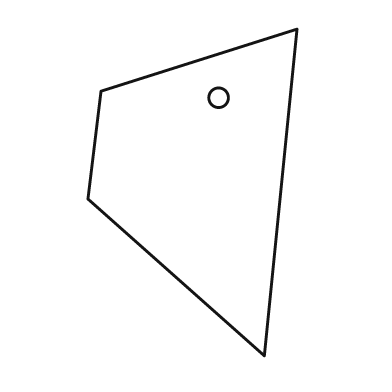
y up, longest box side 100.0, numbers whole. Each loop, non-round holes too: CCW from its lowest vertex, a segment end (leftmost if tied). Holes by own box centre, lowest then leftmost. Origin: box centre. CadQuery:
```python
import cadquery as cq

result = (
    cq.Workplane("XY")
    .moveTo(22.0, -50.0)
    .lineTo(32.0, 50.0)
    .lineTo(-28.0, 31.0)
    .lineTo(-32.0, -2.0)
    .close()
    .moveTo(8.0, 29.0)
    .circle(3.0)
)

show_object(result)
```